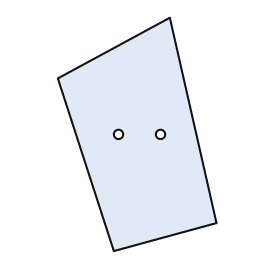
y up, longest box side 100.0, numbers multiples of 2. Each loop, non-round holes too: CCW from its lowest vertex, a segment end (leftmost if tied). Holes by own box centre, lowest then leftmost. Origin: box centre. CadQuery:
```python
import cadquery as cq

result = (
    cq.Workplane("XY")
    .moveTo(-10.0, -50.0)
    .lineTo(34.0, -38.0)
    .lineTo(14.0, 50.0)
    .lineTo(-34.0, 24.0)
    .close()
    .moveTo(-8.0, 0.0)
    .circle(2.0)
    .moveTo(10.0, 0.0)
    .circle(2.0)
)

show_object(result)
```